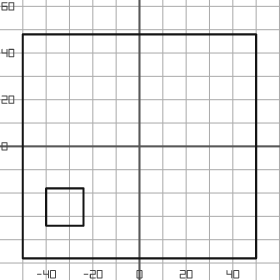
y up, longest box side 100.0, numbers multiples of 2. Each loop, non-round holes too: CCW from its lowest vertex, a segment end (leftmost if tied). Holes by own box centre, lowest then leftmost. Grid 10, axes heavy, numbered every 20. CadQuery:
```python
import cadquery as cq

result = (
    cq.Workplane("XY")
    .moveTo(-50.0, -48.0)
    .lineTo(50.0, -48.0)
    .lineTo(50.0, 48.0)
    .lineTo(-50.0, 48.0)
    .close()
    .moveTo(-40.0, -34.0)
    .lineTo(-24.0, -34.0)
    .lineTo(-24.0, -18.0)
    .lineTo(-40.0, -18.0)
    .close()
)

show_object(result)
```